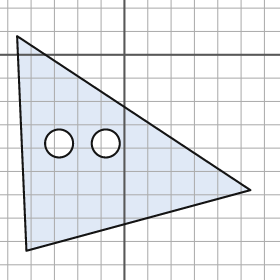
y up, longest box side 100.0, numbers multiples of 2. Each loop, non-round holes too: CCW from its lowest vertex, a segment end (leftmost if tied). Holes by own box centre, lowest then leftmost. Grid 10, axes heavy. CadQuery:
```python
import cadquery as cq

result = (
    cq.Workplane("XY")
    .moveTo(-42.0, -84.0)
    .lineTo(54.0, -58.0)
    .lineTo(-46.0, 8.0)
    .close()
    .moveTo(-28.0, -38.0)
    .circle(6.0)
    .moveTo(-8.0, -38.0)
    .circle(6.0)
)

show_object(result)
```